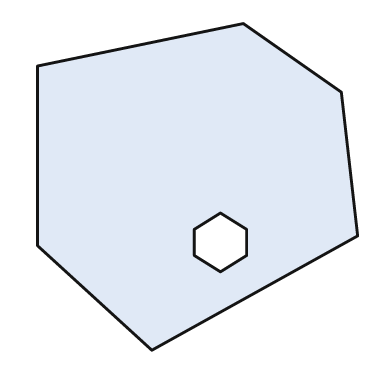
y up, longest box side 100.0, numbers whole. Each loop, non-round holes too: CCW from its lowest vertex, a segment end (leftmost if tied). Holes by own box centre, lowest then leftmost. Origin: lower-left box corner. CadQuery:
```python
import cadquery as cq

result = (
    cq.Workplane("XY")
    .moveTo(35.0, 0.0)
    .lineTo(98.0, 35.0)
    .lineTo(93.0, 79.0)
    .lineTo(63.0, 100.0)
    .lineTo(0.0, 87.0)
    .lineTo(0.0, 32.0)
    .close()
    .moveTo(56.0, 24.0)
    .lineTo(64.0, 29.0)
    .lineTo(64.0, 37.0)
    .lineTo(56.0, 42.0)
    .lineTo(48.0, 37.0)
    .lineTo(48.0, 29.0)
    .close()
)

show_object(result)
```